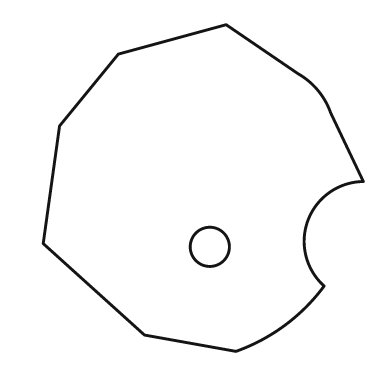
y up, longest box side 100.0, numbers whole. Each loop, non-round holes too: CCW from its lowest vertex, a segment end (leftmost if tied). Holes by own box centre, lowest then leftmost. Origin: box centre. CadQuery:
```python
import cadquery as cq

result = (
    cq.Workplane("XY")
    .moveTo(10.0, -50.0)
    .threePointArc((25.0, -42.0), (37.0, -30.0))
    .threePointArc((32.0, -10.0), (49.0, 2.0))
    .lineTo(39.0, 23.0)
    .threePointArc((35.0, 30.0), (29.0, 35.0))
    .lineTo(7.0, 50.0)
    .lineTo(-26.0, 41.0)
    .lineTo(-44.0, 19.0)
    .lineTo(-49.0, -17.0)
    .lineTo(-18.0, -45.0)
    .close()
    .moveTo(2.0, -18.0)
    .circle(6.0)
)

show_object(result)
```